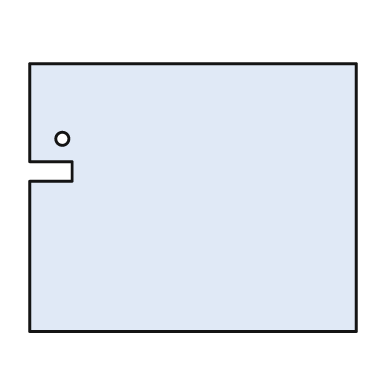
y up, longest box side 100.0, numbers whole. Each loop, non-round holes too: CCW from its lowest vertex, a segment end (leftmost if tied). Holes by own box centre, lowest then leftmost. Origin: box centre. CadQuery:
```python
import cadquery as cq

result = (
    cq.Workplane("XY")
    .moveTo(-50.0, -41.0)
    .lineTo(50.0, -41.0)
    .lineTo(50.0, 41.0)
    .lineTo(-50.0, 41.0)
    .lineTo(-50.0, 11.0)
    .lineTo(-37.0, 11.0)
    .lineTo(-37.0, 5.0)
    .lineTo(-50.0, 5.0)
    .close()
    .moveTo(-40.0, 18.0)
    .circle(2.0)
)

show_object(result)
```